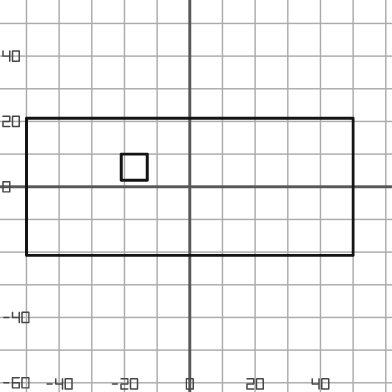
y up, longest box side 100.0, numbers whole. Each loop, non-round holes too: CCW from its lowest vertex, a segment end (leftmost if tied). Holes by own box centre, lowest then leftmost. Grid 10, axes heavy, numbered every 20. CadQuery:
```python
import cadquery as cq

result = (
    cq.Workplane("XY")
    .moveTo(-50.0, -21.0)
    .lineTo(50.0, -21.0)
    .lineTo(50.0, 21.0)
    .lineTo(-50.0, 21.0)
    .close()
    .moveTo(-21.0, 2.0)
    .lineTo(-13.0, 2.0)
    .lineTo(-13.0, 10.0)
    .lineTo(-21.0, 10.0)
    .close()
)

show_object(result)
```